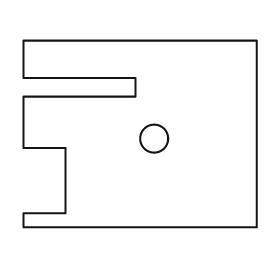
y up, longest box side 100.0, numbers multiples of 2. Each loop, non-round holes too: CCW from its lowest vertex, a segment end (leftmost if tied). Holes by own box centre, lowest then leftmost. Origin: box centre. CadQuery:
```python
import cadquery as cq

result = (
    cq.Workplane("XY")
    .moveTo(-50.0, -40.0)
    .lineTo(50.0, -40.0)
    .lineTo(50.0, 40.0)
    .lineTo(-50.0, 40.0)
    .lineTo(-50.0, 24.0)
    .lineTo(-2.0, 24.0)
    .lineTo(-2.0, 16.0)
    .lineTo(-50.0, 16.0)
    .lineTo(-50.0, -6.0)
    .lineTo(-32.0, -6.0)
    .lineTo(-32.0, -34.0)
    .lineTo(-50.0, -34.0)
    .close()
    .moveTo(6.0, -2.0)
    .circle(6.0)
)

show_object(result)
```